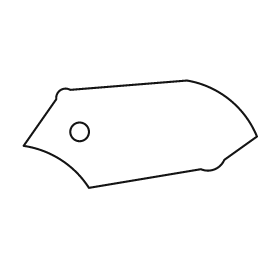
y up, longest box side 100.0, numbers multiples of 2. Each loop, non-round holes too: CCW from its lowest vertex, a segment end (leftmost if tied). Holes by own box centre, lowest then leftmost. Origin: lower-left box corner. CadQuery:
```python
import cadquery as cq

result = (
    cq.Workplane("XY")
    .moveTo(28.0, 0.0)
    .lineTo(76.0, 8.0)
    .threePointArc((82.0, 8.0), (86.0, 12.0))
    .lineTo(100.0, 22.0)
    .threePointArc((88.0, 38.0), (70.0, 46.0))
    .lineTo(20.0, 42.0)
    .threePointArc((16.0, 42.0), (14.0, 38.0))
    .lineTo(0.0, 18.0)
    .threePointArc((16.0, 12.0), (28.0, 0.0))
    .close()
    .moveTo(24.0, 24.0)
    .circle(4.0)
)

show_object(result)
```